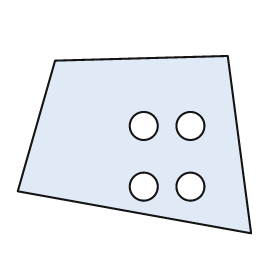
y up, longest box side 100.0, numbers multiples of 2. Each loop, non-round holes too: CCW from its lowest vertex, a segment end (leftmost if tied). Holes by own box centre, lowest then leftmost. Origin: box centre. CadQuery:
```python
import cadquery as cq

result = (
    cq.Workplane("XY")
    .moveTo(50.0, -38.0)
    .lineTo(40.0, 38.0)
    .lineTo(-34.0, 36.0)
    .lineTo(-50.0, -20.0)
    .close()
    .moveTo(4.0, -18.0)
    .circle(6.0)
    .moveTo(24.0, -18.0)
    .circle(6.0)
    .moveTo(4.0, 8.0)
    .circle(6.0)
    .moveTo(24.0, 8.0)
    .circle(6.0)
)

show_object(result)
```